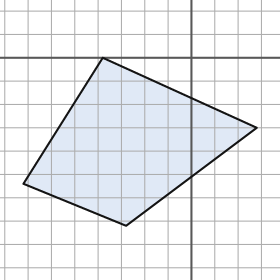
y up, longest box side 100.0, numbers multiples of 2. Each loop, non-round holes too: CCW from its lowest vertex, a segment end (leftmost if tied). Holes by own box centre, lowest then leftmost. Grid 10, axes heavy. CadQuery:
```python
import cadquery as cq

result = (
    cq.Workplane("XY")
    .moveTo(-28.0, -72.0)
    .lineTo(28.0, -30.0)
    .lineTo(-38.0, 0.0)
    .lineTo(-72.0, -54.0)
    .close()
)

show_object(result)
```